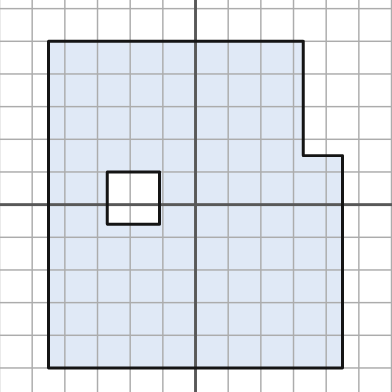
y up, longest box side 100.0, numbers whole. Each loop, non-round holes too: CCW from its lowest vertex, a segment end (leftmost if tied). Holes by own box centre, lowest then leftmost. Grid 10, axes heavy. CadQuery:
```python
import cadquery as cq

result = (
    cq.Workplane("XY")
    .moveTo(-45.0, -50.0)
    .lineTo(45.0, -50.0)
    .lineTo(45.0, 15.0)
    .lineTo(33.0, 15.0)
    .lineTo(33.0, 50.0)
    .lineTo(-45.0, 50.0)
    .close()
    .moveTo(-27.0, -6.0)
    .lineTo(-11.0, -6.0)
    .lineTo(-11.0, 10.0)
    .lineTo(-27.0, 10.0)
    .close()
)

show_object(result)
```